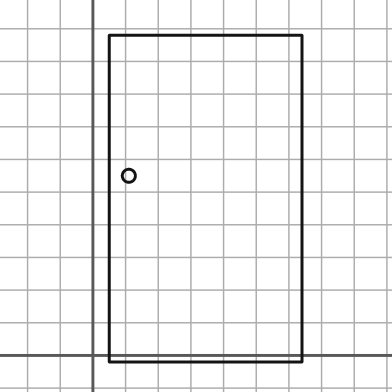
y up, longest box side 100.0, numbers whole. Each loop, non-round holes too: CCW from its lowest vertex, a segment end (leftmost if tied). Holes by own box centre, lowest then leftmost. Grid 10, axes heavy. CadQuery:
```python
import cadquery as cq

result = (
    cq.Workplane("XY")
    .moveTo(5.0, -2.0)
    .lineTo(64.0, -2.0)
    .lineTo(64.0, 98.0)
    .lineTo(5.0, 98.0)
    .close()
    .moveTo(11.0, 55.0)
    .circle(2.0)
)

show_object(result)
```